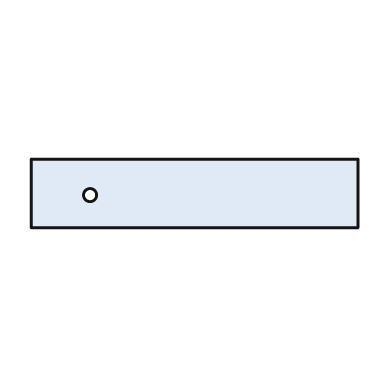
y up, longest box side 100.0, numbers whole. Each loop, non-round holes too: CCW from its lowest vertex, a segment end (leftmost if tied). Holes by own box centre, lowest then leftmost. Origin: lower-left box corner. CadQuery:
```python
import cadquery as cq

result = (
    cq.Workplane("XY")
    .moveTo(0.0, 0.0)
    .lineTo(100.0, 0.0)
    .lineTo(100.0, 21.0)
    .lineTo(0.0, 21.0)
    .close()
    .moveTo(18.0, 10.0)
    .circle(2.0)
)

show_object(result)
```